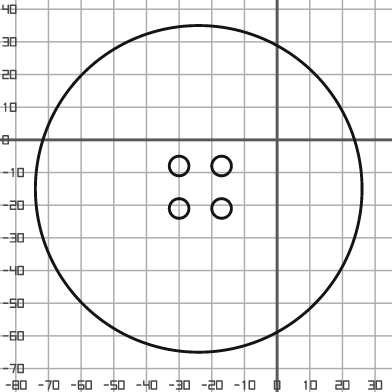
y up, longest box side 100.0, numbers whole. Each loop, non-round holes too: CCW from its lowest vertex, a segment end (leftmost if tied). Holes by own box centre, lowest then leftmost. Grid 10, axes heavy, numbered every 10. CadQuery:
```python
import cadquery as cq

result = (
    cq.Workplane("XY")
    .moveTo(-24.0, -15.0)
    .circle(50.0)
    .moveTo(-30.0, -21.0)
    .circle(3.0)
    .moveTo(-17.0, -21.0)
    .circle(3.0)
    .moveTo(-30.0, -8.0)
    .circle(3.0)
    .moveTo(-17.0, -8.0)
    .circle(3.0)
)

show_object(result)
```